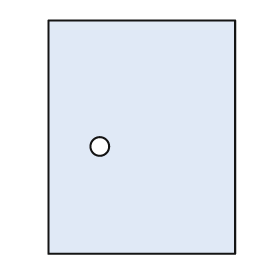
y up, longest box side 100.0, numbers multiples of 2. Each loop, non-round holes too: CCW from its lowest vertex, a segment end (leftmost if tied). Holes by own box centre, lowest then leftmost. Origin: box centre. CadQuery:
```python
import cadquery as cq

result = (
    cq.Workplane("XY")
    .moveTo(-40.0, -50.0)
    .lineTo(40.0, -50.0)
    .lineTo(40.0, 50.0)
    .lineTo(-40.0, 50.0)
    .close()
    .moveTo(-18.0, -4.0)
    .circle(4.0)
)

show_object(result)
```